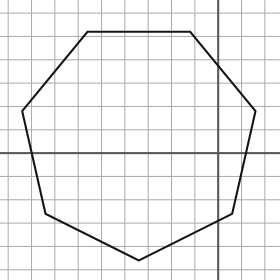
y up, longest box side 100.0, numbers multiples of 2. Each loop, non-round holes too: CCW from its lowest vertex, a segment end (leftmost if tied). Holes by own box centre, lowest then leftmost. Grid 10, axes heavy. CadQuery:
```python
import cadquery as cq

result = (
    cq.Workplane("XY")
    .moveTo(-34.0, -46.0)
    .lineTo(6.0, -26.0)
    .lineTo(16.0, 18.0)
    .lineTo(-12.0, 52.0)
    .lineTo(-56.0, 52.0)
    .lineTo(-84.0, 18.0)
    .lineTo(-74.0, -26.0)
    .close()
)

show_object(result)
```